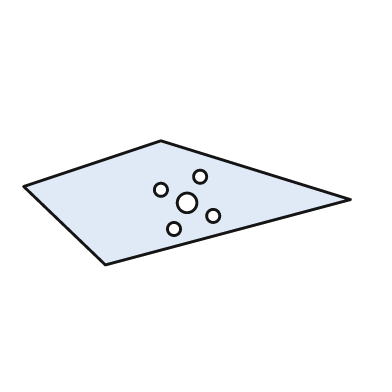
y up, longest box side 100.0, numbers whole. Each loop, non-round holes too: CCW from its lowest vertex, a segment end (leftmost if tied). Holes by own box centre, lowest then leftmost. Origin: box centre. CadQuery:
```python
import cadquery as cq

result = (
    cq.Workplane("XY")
    .moveTo(-25.0, -19.0)
    .lineTo(50.0, 1.0)
    .lineTo(-8.0, 19.0)
    .lineTo(-50.0, 5.0)
    .close()
    .moveTo(-4.0, -8.0)
    .circle(2.0)
    .moveTo(8.0, -4.0)
    .circle(2.0)
    .moveTo(0.0, 0.0)
    .circle(3.0)
    .moveTo(-8.0, 4.0)
    .circle(2.0)
    .moveTo(4.0, 8.0)
    .circle(2.0)
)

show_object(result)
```